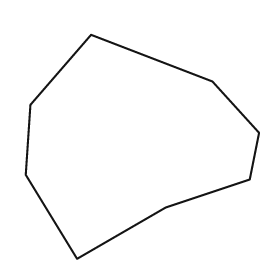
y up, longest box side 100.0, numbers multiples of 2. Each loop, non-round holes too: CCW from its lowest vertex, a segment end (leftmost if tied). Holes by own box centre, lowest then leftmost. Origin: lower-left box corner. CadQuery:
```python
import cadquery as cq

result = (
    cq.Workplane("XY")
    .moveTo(22.0, 0.0)
    .lineTo(60.0, 22.0)
    .lineTo(96.0, 34.0)
    .lineTo(100.0, 54.0)
    .lineTo(80.0, 76.0)
    .lineTo(28.0, 96.0)
    .lineTo(2.0, 66.0)
    .lineTo(0.0, 36.0)
    .close()
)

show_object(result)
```